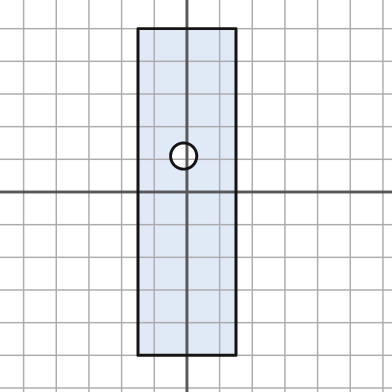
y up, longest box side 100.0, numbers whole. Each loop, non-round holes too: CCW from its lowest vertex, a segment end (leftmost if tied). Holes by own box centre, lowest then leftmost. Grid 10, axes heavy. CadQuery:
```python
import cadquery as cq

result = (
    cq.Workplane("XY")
    .moveTo(-15.0, -50.0)
    .lineTo(15.0, -50.0)
    .lineTo(15.0, 50.0)
    .lineTo(-15.0, 50.0)
    .close()
    .moveTo(-1.0, 11.0)
    .circle(4.0)
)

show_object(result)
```